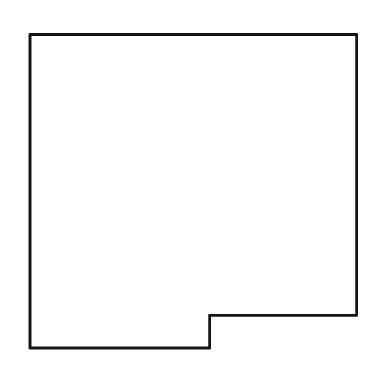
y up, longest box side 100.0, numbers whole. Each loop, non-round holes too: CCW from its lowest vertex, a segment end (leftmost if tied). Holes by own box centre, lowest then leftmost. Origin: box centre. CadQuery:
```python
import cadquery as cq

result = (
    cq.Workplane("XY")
    .moveTo(-50.0, -48.0)
    .lineTo(5.0, -48.0)
    .lineTo(5.0, -38.0)
    .lineTo(50.0, -38.0)
    .lineTo(50.0, 48.0)
    .lineTo(-50.0, 48.0)
    .close()
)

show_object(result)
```